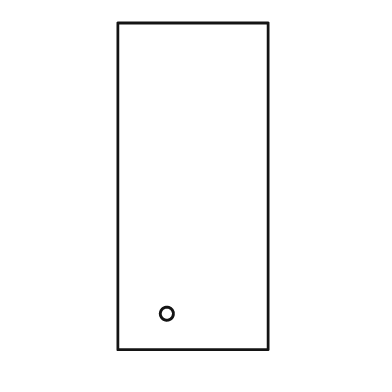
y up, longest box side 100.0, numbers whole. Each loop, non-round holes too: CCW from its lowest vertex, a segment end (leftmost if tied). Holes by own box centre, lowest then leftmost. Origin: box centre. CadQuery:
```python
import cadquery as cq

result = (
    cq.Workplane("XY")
    .moveTo(-23.0, -50.0)
    .lineTo(23.0, -50.0)
    .lineTo(23.0, 50.0)
    .lineTo(-23.0, 50.0)
    .close()
    .moveTo(-8.0, -39.0)
    .circle(2.0)
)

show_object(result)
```